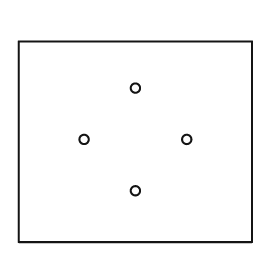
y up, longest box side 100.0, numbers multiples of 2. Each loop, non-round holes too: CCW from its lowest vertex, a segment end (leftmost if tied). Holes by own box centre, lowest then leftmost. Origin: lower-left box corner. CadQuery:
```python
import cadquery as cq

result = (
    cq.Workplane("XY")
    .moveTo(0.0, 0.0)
    .lineTo(100.0, 0.0)
    .lineTo(100.0, 86.0)
    .lineTo(0.0, 86.0)
    .close()
    .moveTo(50.0, 22.0)
    .circle(2.0)
    .moveTo(28.0, 44.0)
    .circle(2.0)
    .moveTo(72.0, 44.0)
    .circle(2.0)
    .moveTo(50.0, 66.0)
    .circle(2.0)
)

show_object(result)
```